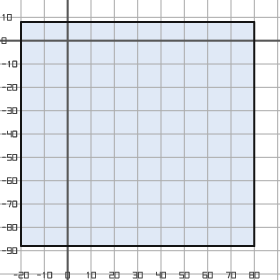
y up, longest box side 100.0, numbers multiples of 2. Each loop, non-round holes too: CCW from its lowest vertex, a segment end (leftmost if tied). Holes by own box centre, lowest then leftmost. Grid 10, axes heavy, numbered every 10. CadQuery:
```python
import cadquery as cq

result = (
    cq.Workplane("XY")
    .moveTo(-20.0, -88.0)
    .lineTo(80.0, -88.0)
    .lineTo(80.0, 8.0)
    .lineTo(-20.0, 8.0)
    .close()
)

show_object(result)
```